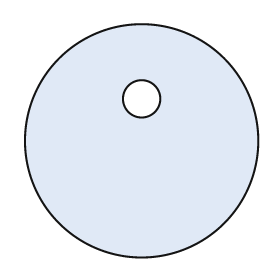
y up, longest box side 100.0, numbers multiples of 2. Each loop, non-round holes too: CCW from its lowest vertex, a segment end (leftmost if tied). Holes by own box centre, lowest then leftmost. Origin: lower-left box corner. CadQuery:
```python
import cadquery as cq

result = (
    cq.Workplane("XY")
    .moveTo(50.0, 50.0)
    .circle(50.0)
    .moveTo(50.0, 68.0)
    .circle(8.0)
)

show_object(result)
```